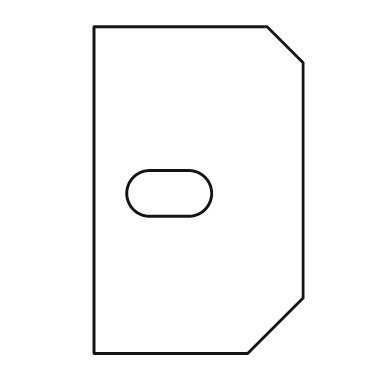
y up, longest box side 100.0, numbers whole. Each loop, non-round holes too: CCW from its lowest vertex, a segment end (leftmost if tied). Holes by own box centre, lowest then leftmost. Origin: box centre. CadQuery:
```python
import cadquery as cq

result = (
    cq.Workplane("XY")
    .moveTo(-32.0, -50.0)
    .lineTo(15.0, -50.0)
    .lineTo(32.0, -33.0)
    .lineTo(32.0, 39.0)
    .lineTo(21.0, 50.0)
    .lineTo(-32.0, 50.0)
    .close()
    .moveTo(-15.0, -8.0)
    .lineTo(-3.0, -8.0)
    .threePointArc((4.0, -1.0), (-3.0, 6.0))
    .lineTo(-15.0, 6.0)
    .threePointArc((-22.0, -1.0), (-15.0, -8.0))
    .close()
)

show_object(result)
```